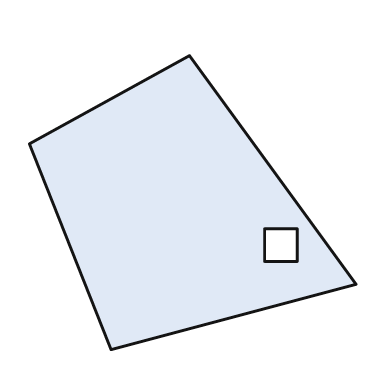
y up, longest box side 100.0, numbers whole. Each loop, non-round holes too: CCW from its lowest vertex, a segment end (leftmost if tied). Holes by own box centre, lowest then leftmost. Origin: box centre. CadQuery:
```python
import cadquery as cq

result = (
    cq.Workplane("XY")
    .moveTo(-25.0, -45.0)
    .lineTo(50.0, -25.0)
    .lineTo(-1.0, 45.0)
    .lineTo(-50.0, 18.0)
    .close()
    .moveTo(22.0, -18.0)
    .lineTo(32.0, -18.0)
    .lineTo(32.0, -8.0)
    .lineTo(22.0, -8.0)
    .close()
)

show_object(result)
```